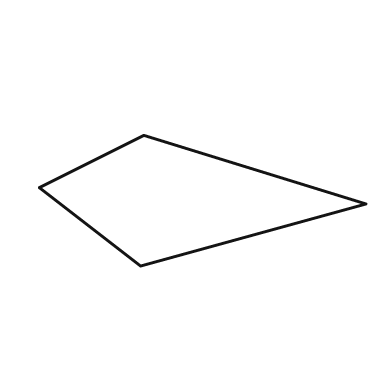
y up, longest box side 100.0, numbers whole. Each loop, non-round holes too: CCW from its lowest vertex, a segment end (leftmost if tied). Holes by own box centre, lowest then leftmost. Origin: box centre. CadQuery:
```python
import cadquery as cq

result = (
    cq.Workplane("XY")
    .moveTo(-19.0, -20.0)
    .lineTo(50.0, -1.0)
    .lineTo(-18.0, 20.0)
    .lineTo(-50.0, 4.0)
    .close()
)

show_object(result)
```